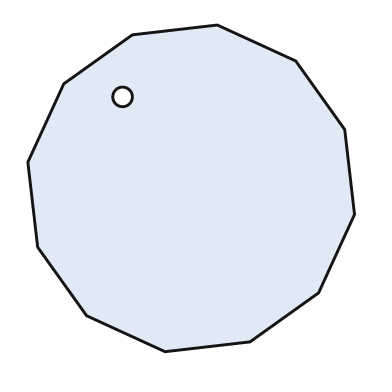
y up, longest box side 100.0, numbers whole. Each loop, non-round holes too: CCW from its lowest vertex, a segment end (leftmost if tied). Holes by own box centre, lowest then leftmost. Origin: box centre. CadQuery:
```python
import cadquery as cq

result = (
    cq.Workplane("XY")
    .moveTo(-8.0, -50.0)
    .lineTo(18.0, -47.0)
    .lineTo(39.0, -32.0)
    .lineTo(50.0, -8.0)
    .lineTo(47.0, 18.0)
    .lineTo(32.0, 39.0)
    .lineTo(8.0, 50.0)
    .lineTo(-18.0, 47.0)
    .lineTo(-39.0, 32.0)
    .lineTo(-50.0, 8.0)
    .lineTo(-47.0, -18.0)
    .lineTo(-32.0, -39.0)
    .close()
    .moveTo(-21.0, 28.0)
    .circle(3.0)
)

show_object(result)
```